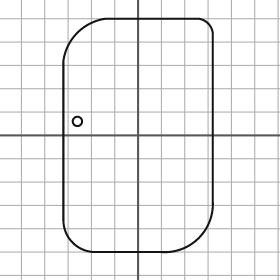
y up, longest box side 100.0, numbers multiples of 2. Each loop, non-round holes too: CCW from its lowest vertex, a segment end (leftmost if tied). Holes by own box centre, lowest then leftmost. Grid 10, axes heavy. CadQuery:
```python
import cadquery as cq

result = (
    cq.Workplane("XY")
    .moveTo(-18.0, -50.0)
    .lineTo(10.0, -50.0)
    .threePointArc((26.0, -44.0), (32.0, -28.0))
    .lineTo(32.0, 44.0)
    .threePointArc((30.0, 48.0), (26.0, 50.0))
    .lineTo(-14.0, 50.0)
    .threePointArc((-26.0, 44.0), (-32.0, 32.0))
    .lineTo(-32.0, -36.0)
    .threePointArc((-28.0, -46.0), (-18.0, -50.0))
    .close()
    .moveTo(-26.0, 6.0)
    .circle(2.0)
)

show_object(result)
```